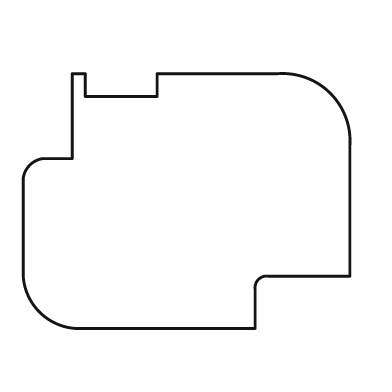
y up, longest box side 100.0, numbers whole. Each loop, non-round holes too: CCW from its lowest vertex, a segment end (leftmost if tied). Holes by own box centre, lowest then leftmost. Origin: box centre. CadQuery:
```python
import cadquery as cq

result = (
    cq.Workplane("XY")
    .moveTo(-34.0, -39.0)
    .lineTo(21.0, -39.0)
    .lineTo(21.0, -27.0)
    .threePointArc((22.0, -24.0), (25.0, -23.0))
    .lineTo(50.0, -23.0)
    .lineTo(50.0, 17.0)
    .threePointArc((44.0, 33.0), (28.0, 39.0))
    .lineTo(-9.0, 39.0)
    .lineTo(-9.0, 32.0)
    .lineTo(-31.0, 32.0)
    .lineTo(-31.0, 39.0)
    .lineTo(-35.0, 39.0)
    .lineTo(-35.0, 13.0)
    .lineTo(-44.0, 13.0)
    .threePointArc((-48.0, 11.0), (-50.0, 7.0))
    .lineTo(-50.0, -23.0)
    .threePointArc((-45.0, -34.0), (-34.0, -39.0))
    .close()
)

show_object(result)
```